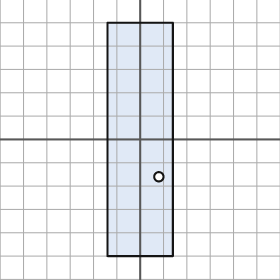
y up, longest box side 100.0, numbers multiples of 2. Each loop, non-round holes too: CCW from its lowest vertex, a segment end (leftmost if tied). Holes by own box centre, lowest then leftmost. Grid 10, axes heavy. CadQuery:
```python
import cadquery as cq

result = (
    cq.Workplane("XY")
    .moveTo(-14.0, -50.0)
    .lineTo(14.0, -50.0)
    .lineTo(14.0, 50.0)
    .lineTo(-14.0, 50.0)
    .close()
    .moveTo(8.0, -16.0)
    .circle(2.0)
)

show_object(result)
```